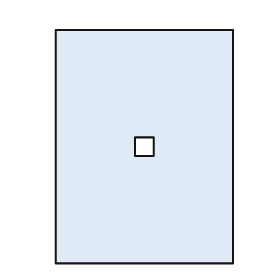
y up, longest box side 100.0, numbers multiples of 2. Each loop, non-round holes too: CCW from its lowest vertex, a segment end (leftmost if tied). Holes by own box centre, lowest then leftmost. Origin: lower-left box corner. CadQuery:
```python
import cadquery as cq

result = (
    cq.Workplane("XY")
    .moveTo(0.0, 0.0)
    .lineTo(76.0, 0.0)
    .lineTo(76.0, 100.0)
    .lineTo(0.0, 100.0)
    .close()
    .moveTo(34.0, 46.0)
    .lineTo(42.0, 46.0)
    .lineTo(42.0, 54.0)
    .lineTo(34.0, 54.0)
    .close()
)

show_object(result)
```